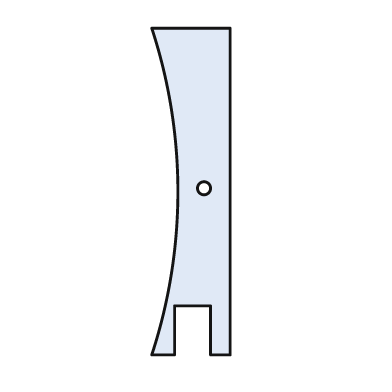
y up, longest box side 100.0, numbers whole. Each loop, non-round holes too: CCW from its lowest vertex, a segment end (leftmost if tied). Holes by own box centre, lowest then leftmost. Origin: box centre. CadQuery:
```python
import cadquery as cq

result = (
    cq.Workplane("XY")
    .moveTo(-12.0, -50.0)
    .lineTo(-5.0, -50.0)
    .lineTo(-5.0, -35.0)
    .lineTo(6.0, -35.0)
    .lineTo(6.0, -50.0)
    .lineTo(12.0, -50.0)
    .lineTo(12.0, 50.0)
    .lineTo(-12.0, 50.0)
    .threePointArc((-4.0, 0.0), (-12.0, -50.0))
    .close()
    .moveTo(4.0, 1.0)
    .circle(2.0)
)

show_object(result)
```